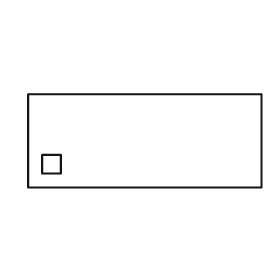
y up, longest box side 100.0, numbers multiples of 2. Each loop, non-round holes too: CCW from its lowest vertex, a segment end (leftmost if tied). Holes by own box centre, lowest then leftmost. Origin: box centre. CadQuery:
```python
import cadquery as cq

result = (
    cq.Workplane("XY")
    .moveTo(-50.0, -20.0)
    .lineTo(50.0, -20.0)
    .lineTo(50.0, 20.0)
    .lineTo(-50.0, 20.0)
    .close()
    .moveTo(-44.0, -14.0)
    .lineTo(-36.0, -14.0)
    .lineTo(-36.0, -6.0)
    .lineTo(-44.0, -6.0)
    .close()
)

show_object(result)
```